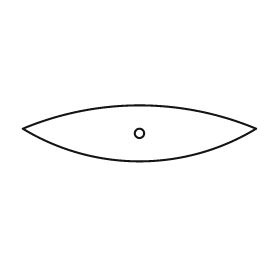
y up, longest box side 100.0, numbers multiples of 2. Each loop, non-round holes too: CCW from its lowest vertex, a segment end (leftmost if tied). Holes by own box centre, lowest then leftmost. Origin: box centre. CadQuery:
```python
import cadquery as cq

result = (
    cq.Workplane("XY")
    .moveTo(-50.0, 2.0)
    .threePointArc((0.0, -12.0), (50.0, 2.0))
    .threePointArc((0.0, 12.0), (-50.0, 2.0))
    .close()
    .moveTo(0.0, 0.0)
    .circle(2.0)
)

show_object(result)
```